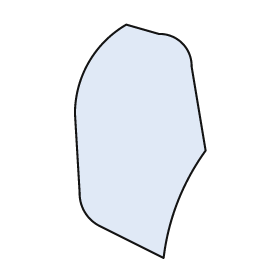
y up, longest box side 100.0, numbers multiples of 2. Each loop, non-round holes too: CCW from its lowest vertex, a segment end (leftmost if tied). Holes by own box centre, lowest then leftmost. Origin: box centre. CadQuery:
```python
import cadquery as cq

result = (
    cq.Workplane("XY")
    .moveTo(10.0, -50.0)
    .threePointArc((16.0, -26.0), (28.0, -4.0))
    .lineTo(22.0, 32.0)
    .threePointArc((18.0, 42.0), (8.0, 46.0))
    .lineTo(-6.0, 50.0)
    .threePointArc((-22.0, 34.0), (-28.0, 12.0))
    .lineTo(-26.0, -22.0)
    .threePointArc((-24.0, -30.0), (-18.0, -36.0))
    .close()
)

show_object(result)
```